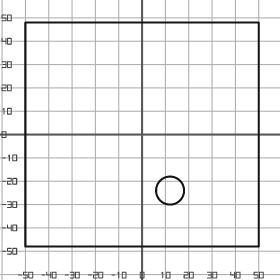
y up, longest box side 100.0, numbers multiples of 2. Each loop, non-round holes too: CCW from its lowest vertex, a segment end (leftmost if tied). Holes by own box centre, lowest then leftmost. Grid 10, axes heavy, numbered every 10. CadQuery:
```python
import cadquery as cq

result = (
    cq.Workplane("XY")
    .moveTo(-50.0, -48.0)
    .lineTo(50.0, -48.0)
    .lineTo(50.0, 48.0)
    .lineTo(-50.0, 48.0)
    .close()
    .moveTo(12.0, -24.0)
    .circle(6.0)
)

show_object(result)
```